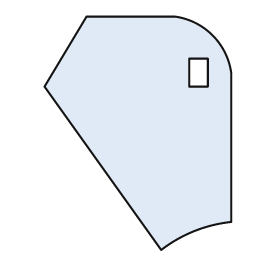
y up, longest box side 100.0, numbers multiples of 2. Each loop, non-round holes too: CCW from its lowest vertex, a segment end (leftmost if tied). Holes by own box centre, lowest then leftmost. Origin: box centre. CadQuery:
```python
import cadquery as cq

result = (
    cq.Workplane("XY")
    .moveTo(10.0, -50.0)
    .threePointArc((24.0, -42.0), (40.0, -38.0))
    .lineTo(40.0, 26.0)
    .threePointArc((32.0, 42.0), (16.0, 50.0))
    .lineTo(-22.0, 50.0)
    .lineTo(-40.0, 20.0)
    .close()
    .moveTo(22.0, 20.0)
    .lineTo(30.0, 20.0)
    .lineTo(30.0, 32.0)
    .lineTo(22.0, 32.0)
    .close()
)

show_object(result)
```